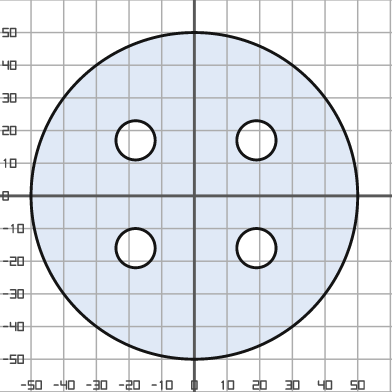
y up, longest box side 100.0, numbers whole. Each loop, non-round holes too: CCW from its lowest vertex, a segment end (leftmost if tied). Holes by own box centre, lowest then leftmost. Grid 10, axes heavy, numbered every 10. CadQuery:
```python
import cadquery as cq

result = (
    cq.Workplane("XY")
    .moveTo(0.0, 0.0)
    .circle(50.0)
    .moveTo(-18.0, -16.0)
    .circle(6.0)
    .moveTo(19.0, -16.0)
    .circle(6.0)
    .moveTo(-18.0, 17.0)
    .circle(6.0)
    .moveTo(19.0, 17.0)
    .circle(6.0)
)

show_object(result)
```